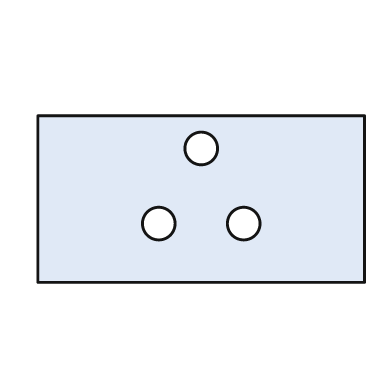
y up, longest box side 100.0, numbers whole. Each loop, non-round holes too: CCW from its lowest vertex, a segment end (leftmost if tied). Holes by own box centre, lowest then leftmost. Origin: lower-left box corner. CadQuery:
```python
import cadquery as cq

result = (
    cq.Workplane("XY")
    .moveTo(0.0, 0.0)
    .lineTo(100.0, 0.0)
    .lineTo(100.0, 51.0)
    .lineTo(0.0, 51.0)
    .close()
    .moveTo(37.0, 18.0)
    .circle(5.0)
    .moveTo(63.0, 18.0)
    .circle(5.0)
    .moveTo(50.0, 41.0)
    .circle(5.0)
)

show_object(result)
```